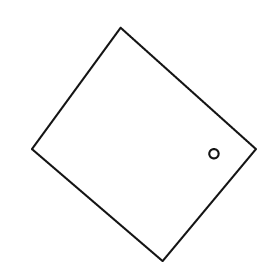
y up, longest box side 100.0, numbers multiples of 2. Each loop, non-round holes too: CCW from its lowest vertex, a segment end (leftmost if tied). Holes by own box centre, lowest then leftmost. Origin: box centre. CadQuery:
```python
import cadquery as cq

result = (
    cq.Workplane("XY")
    .moveTo(8.0, -50.0)
    .lineTo(48.0, -2.0)
    .lineTo(-10.0, 50.0)
    .lineTo(-48.0, -2.0)
    .close()
    .moveTo(30.0, -4.0)
    .circle(2.0)
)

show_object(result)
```